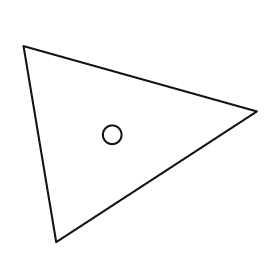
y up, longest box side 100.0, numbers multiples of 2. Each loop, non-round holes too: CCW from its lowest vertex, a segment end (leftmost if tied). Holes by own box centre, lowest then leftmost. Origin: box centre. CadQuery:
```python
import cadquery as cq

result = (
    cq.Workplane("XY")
    .moveTo(-36.0, -42.0)
    .lineTo(50.0, 14.0)
    .lineTo(-50.0, 42.0)
    .close()
    .moveTo(-12.0, 4.0)
    .circle(4.0)
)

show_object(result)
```